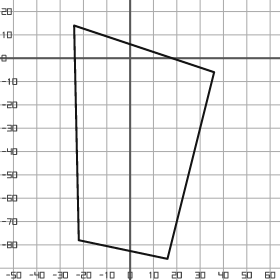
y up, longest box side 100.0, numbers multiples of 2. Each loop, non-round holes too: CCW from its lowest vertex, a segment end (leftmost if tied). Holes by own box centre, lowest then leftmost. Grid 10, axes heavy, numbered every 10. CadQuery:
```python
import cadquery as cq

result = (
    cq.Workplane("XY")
    .moveTo(16.0, -86.0)
    .lineTo(36.0, -6.0)
    .lineTo(-24.0, 14.0)
    .lineTo(-22.0, -78.0)
    .close()
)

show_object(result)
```